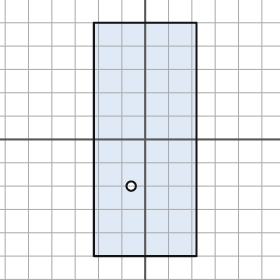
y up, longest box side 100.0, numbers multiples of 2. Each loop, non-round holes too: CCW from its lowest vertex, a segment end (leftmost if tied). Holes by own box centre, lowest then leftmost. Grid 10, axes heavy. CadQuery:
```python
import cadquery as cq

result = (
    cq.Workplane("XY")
    .moveTo(-22.0, -50.0)
    .lineTo(22.0, -50.0)
    .lineTo(22.0, 50.0)
    .lineTo(-22.0, 50.0)
    .close()
    .moveTo(-6.0, -20.0)
    .circle(2.0)
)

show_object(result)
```